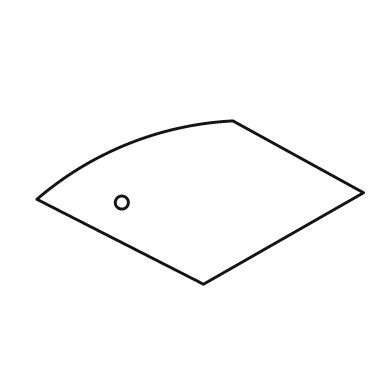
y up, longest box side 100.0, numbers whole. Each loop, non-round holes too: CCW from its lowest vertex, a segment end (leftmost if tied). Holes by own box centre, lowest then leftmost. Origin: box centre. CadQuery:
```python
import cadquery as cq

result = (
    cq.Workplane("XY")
    .moveTo(1.0, -25.0)
    .lineTo(50.0, 3.0)
    .lineTo(10.0, 25.0)
    .threePointArc((-22.0, 18.0), (-50.0, 1.0))
    .close()
    .moveTo(-24.0, 0.0)
    .circle(2.0)
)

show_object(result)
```